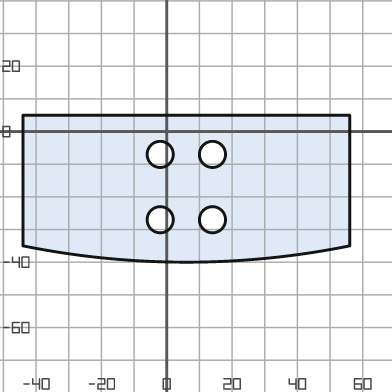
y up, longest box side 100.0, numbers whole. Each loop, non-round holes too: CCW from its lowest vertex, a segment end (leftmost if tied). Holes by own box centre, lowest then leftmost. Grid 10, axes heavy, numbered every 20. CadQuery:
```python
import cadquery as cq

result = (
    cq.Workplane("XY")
    .moveTo(-44.0, -35.0)
    .threePointArc((6.0, -40.0), (56.0, -35.0))
    .lineTo(56.0, 5.0)
    .lineTo(-44.0, 5.0)
    .close()
    .moveTo(-2.0, -27.0)
    .circle(4.0)
    .moveTo(14.0, -27.0)
    .circle(4.0)
    .moveTo(-2.0, -7.0)
    .circle(4.0)
    .moveTo(14.0, -7.0)
    .circle(4.0)
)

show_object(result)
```